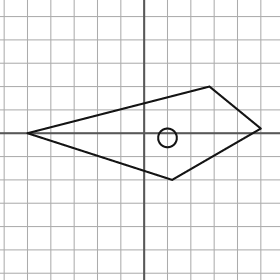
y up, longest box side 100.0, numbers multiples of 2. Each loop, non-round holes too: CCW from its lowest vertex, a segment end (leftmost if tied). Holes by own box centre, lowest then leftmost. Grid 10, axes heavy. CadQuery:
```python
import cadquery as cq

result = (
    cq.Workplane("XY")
    .moveTo(12.0, -20.0)
    .lineTo(50.0, 2.0)
    .lineTo(28.0, 20.0)
    .lineTo(-50.0, 0.0)
    .close()
    .moveTo(10.0, -2.0)
    .circle(4.0)
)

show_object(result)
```